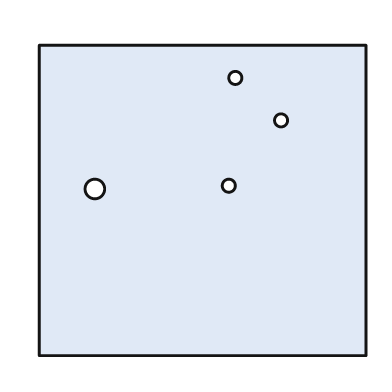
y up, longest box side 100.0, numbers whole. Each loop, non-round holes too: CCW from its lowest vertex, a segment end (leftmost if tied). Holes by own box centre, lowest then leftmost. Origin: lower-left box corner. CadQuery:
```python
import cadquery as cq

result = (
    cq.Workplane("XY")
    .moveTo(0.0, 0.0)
    .lineTo(100.0, 0.0)
    .lineTo(100.0, 95.0)
    .lineTo(0.0, 95.0)
    .close()
    .moveTo(17.0, 51.0)
    .circle(3.0)
    .moveTo(58.0, 52.0)
    .circle(2.0)
    .moveTo(74.0, 72.0)
    .circle(2.0)
    .moveTo(60.0, 85.0)
    .circle(2.0)
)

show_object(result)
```